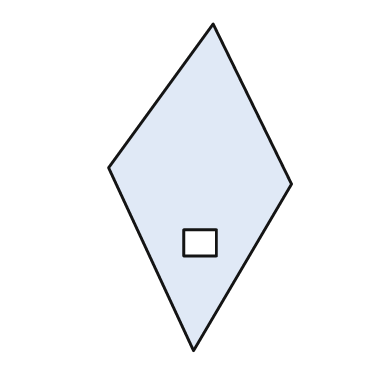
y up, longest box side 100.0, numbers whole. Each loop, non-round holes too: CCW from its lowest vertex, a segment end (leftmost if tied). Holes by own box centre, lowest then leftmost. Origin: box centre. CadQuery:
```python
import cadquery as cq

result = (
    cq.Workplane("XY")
    .moveTo(-2.0, -50.0)
    .lineTo(28.0, 1.0)
    .lineTo(4.0, 50.0)
    .lineTo(-28.0, 6.0)
    .close()
    .moveTo(-5.0, -21.0)
    .lineTo(5.0, -21.0)
    .lineTo(5.0, -13.0)
    .lineTo(-5.0, -13.0)
    .close()
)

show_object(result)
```